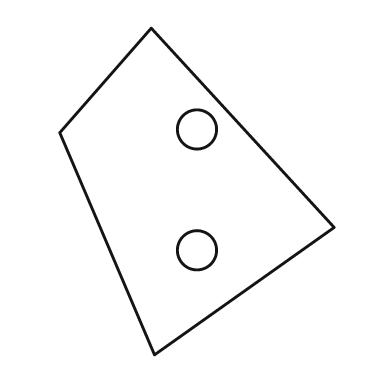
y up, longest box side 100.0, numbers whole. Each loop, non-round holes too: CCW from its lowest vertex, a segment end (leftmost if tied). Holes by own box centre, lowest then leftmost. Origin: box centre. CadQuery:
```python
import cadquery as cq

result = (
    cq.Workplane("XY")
    .moveTo(-13.0, -50.0)
    .lineTo(42.0, -11.0)
    .lineTo(-14.0, 50.0)
    .lineTo(-42.0, 18.0)
    .close()
    .moveTo(0.0, -18.0)
    .circle(6.0)
    .moveTo(0.0, 19.0)
    .circle(6.0)
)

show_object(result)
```